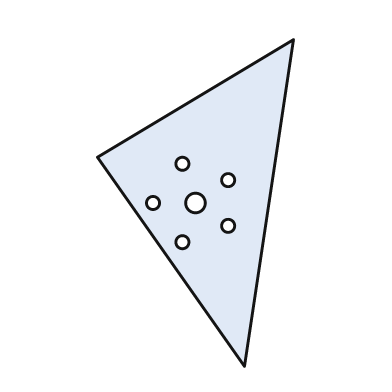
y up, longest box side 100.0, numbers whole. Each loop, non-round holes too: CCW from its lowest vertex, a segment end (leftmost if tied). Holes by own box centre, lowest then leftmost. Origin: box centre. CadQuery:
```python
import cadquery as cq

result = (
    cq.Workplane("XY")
    .moveTo(15.0, -50.0)
    .lineTo(30.0, 50.0)
    .lineTo(-30.0, 14.0)
    .close()
    .moveTo(-4.0, -12.0)
    .circle(2.0)
    .moveTo(10.0, -7.0)
    .circle(2.0)
    .moveTo(-13.0, 0.0)
    .circle(2.0)
    .moveTo(0.0, 0.0)
    .circle(3.0)
    .moveTo(10.0, 7.0)
    .circle(2.0)
    .moveTo(-4.0, 12.0)
    .circle(2.0)
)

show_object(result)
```